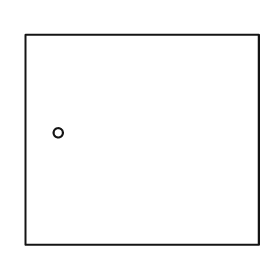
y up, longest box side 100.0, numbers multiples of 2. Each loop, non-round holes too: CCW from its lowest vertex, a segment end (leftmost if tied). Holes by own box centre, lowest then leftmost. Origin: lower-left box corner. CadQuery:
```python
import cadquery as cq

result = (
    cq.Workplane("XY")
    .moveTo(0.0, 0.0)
    .lineTo(100.0, 0.0)
    .lineTo(100.0, 90.0)
    .lineTo(0.0, 90.0)
    .close()
    .moveTo(14.0, 48.0)
    .circle(2.0)
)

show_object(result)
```